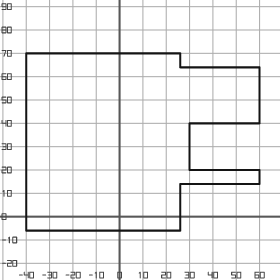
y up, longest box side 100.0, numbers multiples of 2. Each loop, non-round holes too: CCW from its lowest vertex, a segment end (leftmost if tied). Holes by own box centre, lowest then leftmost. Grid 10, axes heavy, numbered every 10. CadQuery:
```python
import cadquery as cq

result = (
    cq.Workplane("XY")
    .moveTo(-40.0, -6.0)
    .lineTo(26.0, -6.0)
    .lineTo(26.0, 14.0)
    .lineTo(60.0, 14.0)
    .lineTo(60.0, 20.0)
    .lineTo(30.0, 20.0)
    .lineTo(30.0, 40.0)
    .lineTo(60.0, 40.0)
    .lineTo(60.0, 64.0)
    .lineTo(26.0, 64.0)
    .lineTo(26.0, 70.0)
    .lineTo(-40.0, 70.0)
    .close()
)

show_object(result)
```